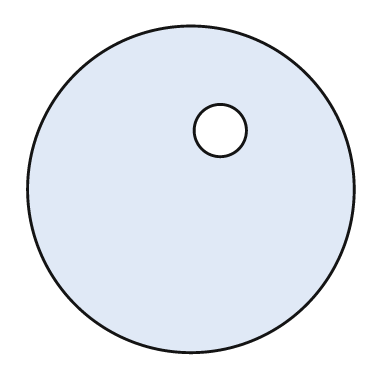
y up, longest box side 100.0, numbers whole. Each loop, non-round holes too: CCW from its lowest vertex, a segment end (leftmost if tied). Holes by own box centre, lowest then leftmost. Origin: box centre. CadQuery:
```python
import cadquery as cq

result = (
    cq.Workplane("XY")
    .moveTo(0.0, 0.0)
    .circle(50.0)
    .moveTo(9.0, 18.0)
    .circle(8.0)
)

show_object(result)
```